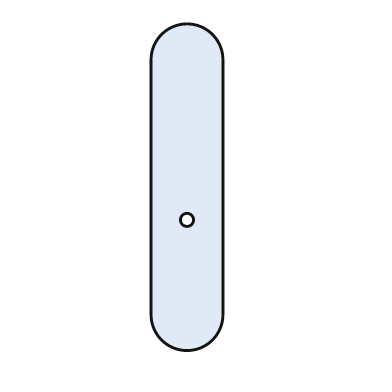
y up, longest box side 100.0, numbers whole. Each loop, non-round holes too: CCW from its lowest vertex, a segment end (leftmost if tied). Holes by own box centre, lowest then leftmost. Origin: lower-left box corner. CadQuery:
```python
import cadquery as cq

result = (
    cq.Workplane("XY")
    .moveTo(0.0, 11.0)
    .threePointArc((11.0, 0.0), (22.0, 11.0))
    .lineTo(22.0, 89.0)
    .threePointArc((11.0, 100.0), (0.0, 89.0))
    .close()
    .moveTo(11.0, 40.0)
    .circle(2.0)
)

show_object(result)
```